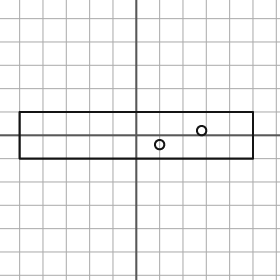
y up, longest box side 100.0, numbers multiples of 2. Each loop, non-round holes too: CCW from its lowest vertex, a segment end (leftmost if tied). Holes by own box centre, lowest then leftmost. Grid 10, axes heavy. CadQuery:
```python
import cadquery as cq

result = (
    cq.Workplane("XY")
    .moveTo(-50.0, -10.0)
    .lineTo(50.0, -10.0)
    .lineTo(50.0, 10.0)
    .lineTo(-50.0, 10.0)
    .close()
    .moveTo(10.0, -4.0)
    .circle(2.0)
    .moveTo(28.0, 2.0)
    .circle(2.0)
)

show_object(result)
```